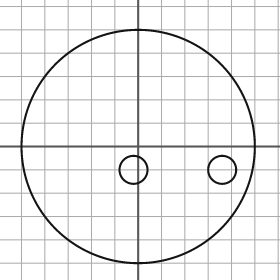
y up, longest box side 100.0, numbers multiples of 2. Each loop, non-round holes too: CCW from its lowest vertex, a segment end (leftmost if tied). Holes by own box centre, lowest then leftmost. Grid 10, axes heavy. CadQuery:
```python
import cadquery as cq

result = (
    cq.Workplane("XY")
    .moveTo(0.0, 0.0)
    .circle(50.0)
    .moveTo(-2.0, -10.0)
    .circle(6.0)
    .moveTo(36.0, -10.0)
    .circle(6.0)
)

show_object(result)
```